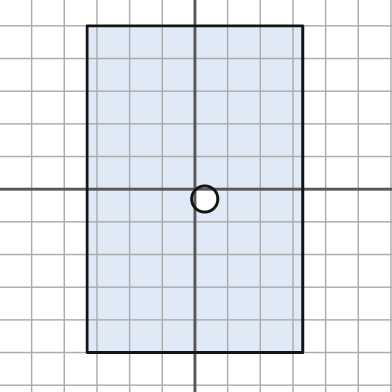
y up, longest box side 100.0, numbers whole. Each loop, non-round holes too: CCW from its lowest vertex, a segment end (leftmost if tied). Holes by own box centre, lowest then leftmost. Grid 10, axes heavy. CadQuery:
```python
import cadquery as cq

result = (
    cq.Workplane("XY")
    .moveTo(-33.0, -50.0)
    .lineTo(33.0, -50.0)
    .lineTo(33.0, 50.0)
    .lineTo(-33.0, 50.0)
    .close()
    .moveTo(3.0, -3.0)
    .circle(4.0)
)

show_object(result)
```